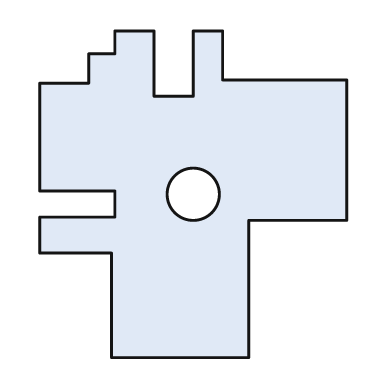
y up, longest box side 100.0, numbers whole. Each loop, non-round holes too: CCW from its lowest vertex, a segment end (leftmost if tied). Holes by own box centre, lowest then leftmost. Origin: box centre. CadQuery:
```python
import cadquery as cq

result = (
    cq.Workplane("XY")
    .moveTo(-25.0, -50.0)
    .lineTo(17.0, -50.0)
    .lineTo(17.0, -8.0)
    .lineTo(47.0, -8.0)
    .lineTo(47.0, 35.0)
    .lineTo(9.0, 35.0)
    .lineTo(9.0, 50.0)
    .lineTo(0.0, 50.0)
    .lineTo(0.0, 30.0)
    .lineTo(-12.0, 30.0)
    .lineTo(-12.0, 50.0)
    .lineTo(-24.0, 50.0)
    .lineTo(-24.0, 43.0)
    .lineTo(-32.0, 43.0)
    .lineTo(-32.0, 34.0)
    .lineTo(-47.0, 34.0)
    .lineTo(-47.0, 1.0)
    .lineTo(-24.0, 1.0)
    .lineTo(-24.0, -7.0)
    .lineTo(-47.0, -7.0)
    .lineTo(-47.0, -18.0)
    .lineTo(-25.0, -18.0)
    .close()
    .moveTo(0.0, 0.0)
    .circle(8.0)
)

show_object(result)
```